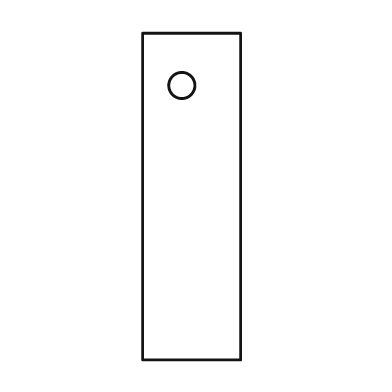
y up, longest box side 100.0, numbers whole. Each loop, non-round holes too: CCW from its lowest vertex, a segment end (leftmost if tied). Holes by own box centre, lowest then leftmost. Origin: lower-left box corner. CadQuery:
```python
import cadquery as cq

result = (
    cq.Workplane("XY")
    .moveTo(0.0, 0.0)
    .lineTo(30.0, 0.0)
    .lineTo(30.0, 100.0)
    .lineTo(0.0, 100.0)
    .close()
    .moveTo(12.0, 84.0)
    .circle(4.0)
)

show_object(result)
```